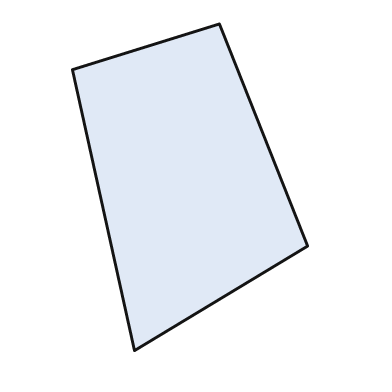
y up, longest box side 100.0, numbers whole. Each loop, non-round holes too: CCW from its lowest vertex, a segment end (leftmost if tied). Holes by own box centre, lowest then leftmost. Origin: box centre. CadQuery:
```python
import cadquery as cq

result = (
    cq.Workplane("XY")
    .moveTo(-17.0, -50.0)
    .lineTo(36.0, -18.0)
    .lineTo(9.0, 50.0)
    .lineTo(-36.0, 36.0)
    .close()
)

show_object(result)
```